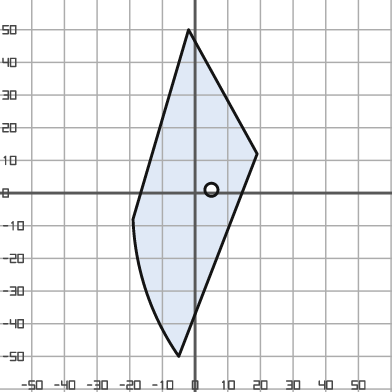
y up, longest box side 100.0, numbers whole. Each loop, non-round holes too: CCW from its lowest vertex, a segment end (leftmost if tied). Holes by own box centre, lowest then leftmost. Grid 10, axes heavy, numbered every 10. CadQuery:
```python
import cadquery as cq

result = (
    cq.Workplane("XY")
    .moveTo(-5.0, -50.0)
    .lineTo(19.0, 12.0)
    .lineTo(-2.0, 50.0)
    .lineTo(-19.0, -8.0)
    .threePointArc((-15.0, -30.0), (-5.0, -50.0))
    .close()
    .moveTo(5.0, 1.0)
    .circle(2.0)
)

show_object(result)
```